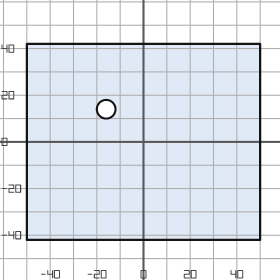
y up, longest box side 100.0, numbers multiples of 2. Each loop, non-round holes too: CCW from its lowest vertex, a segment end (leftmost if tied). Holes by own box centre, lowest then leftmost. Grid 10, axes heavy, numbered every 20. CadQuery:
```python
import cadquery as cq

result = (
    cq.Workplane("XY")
    .moveTo(-50.0, -42.0)
    .lineTo(50.0, -42.0)
    .lineTo(50.0, 42.0)
    .lineTo(-50.0, 42.0)
    .close()
    .moveTo(-16.0, 14.0)
    .circle(4.0)
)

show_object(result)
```